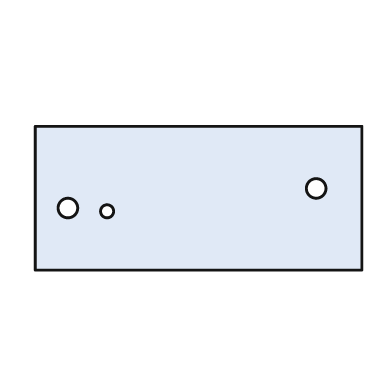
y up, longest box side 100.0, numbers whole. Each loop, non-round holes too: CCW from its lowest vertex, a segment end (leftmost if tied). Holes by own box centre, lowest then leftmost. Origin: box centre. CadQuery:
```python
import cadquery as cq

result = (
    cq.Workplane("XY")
    .moveTo(-50.0, -22.0)
    .lineTo(50.0, -22.0)
    .lineTo(50.0, 22.0)
    .lineTo(-50.0, 22.0)
    .close()
    .moveTo(-28.0, -4.0)
    .circle(2.0)
    .moveTo(-40.0, -3.0)
    .circle(3.0)
    .moveTo(36.0, 3.0)
    .circle(3.0)
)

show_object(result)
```